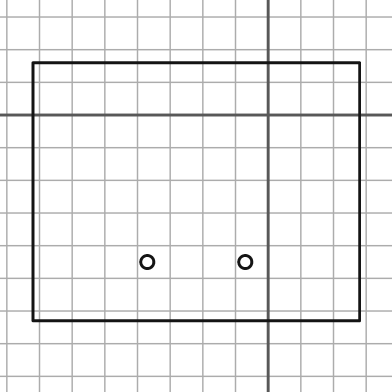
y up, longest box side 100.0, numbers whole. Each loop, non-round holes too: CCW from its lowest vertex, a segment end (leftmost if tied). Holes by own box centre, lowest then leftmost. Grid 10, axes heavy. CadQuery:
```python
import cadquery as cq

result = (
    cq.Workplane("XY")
    .moveTo(-72.0, -63.0)
    .lineTo(28.0, -63.0)
    .lineTo(28.0, 16.0)
    .lineTo(-72.0, 16.0)
    .close()
    .moveTo(-37.0, -45.0)
    .circle(2.0)
    .moveTo(-7.0, -45.0)
    .circle(2.0)
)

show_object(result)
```